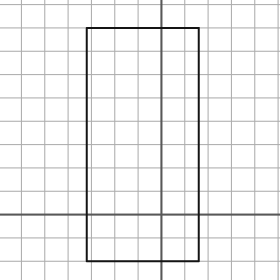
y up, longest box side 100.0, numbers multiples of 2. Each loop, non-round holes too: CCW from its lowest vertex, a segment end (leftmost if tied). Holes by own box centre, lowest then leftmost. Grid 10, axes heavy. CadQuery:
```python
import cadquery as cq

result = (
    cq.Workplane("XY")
    .moveTo(-32.0, -20.0)
    .lineTo(16.0, -20.0)
    .lineTo(16.0, 80.0)
    .lineTo(-32.0, 80.0)
    .close()
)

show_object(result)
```